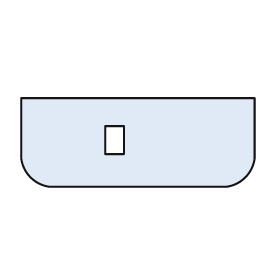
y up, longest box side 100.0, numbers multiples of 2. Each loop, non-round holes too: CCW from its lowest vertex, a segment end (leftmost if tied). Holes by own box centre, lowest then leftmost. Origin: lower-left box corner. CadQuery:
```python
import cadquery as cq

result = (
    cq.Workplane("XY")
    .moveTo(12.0, 0.0)
    .lineTo(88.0, 0.0)
    .threePointArc((96.0, 4.0), (100.0, 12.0))
    .lineTo(100.0, 38.0)
    .lineTo(0.0, 38.0)
    .lineTo(0.0, 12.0)
    .threePointArc((4.0, 4.0), (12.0, 0.0))
    .close()
    .moveTo(36.0, 14.0)
    .lineTo(44.0, 14.0)
    .lineTo(44.0, 26.0)
    .lineTo(36.0, 26.0)
    .close()
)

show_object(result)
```